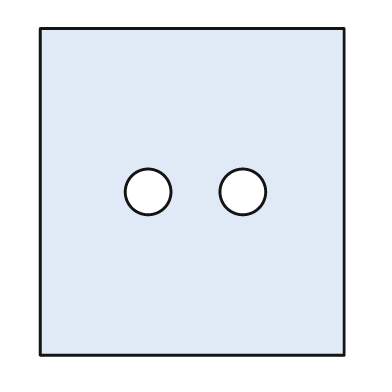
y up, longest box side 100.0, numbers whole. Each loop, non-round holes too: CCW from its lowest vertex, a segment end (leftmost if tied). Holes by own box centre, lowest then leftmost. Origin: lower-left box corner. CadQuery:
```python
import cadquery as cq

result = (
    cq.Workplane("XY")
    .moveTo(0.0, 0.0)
    .lineTo(93.0, 0.0)
    .lineTo(93.0, 100.0)
    .lineTo(0.0, 100.0)
    .close()
    .moveTo(33.0, 50.0)
    .circle(7.0)
    .moveTo(62.0, 50.0)
    .circle(7.0)
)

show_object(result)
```